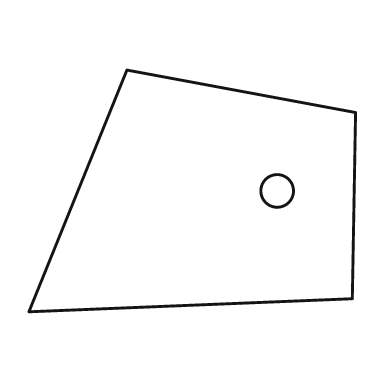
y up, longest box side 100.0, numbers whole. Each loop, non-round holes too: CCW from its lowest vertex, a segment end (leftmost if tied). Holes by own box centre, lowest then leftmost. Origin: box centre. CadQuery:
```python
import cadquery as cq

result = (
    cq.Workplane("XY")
    .moveTo(-50.0, -37.0)
    .lineTo(49.0, -33.0)
    .lineTo(50.0, 24.0)
    .lineTo(-20.0, 37.0)
    .close()
    .moveTo(26.0, 0.0)
    .circle(5.0)
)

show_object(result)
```